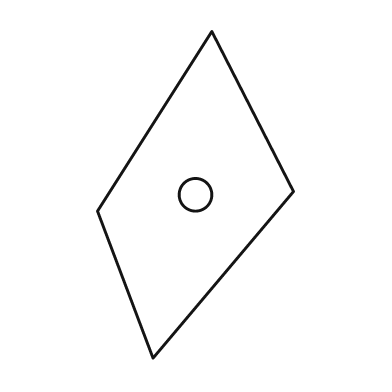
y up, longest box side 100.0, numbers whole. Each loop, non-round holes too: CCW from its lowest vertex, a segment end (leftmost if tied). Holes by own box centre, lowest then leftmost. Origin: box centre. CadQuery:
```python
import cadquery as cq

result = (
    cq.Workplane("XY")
    .moveTo(-13.0, -50.0)
    .lineTo(30.0, 1.0)
    .lineTo(5.0, 50.0)
    .lineTo(-30.0, -5.0)
    .close()
    .moveTo(0.0, 0.0)
    .circle(5.0)
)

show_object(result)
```